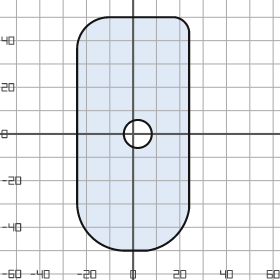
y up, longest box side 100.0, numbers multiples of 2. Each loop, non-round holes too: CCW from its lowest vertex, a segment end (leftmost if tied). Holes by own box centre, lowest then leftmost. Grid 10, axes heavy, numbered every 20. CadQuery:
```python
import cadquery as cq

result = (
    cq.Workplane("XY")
    .moveTo(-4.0, -50.0)
    .lineTo(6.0, -50.0)
    .threePointArc((18.0, -44.0), (24.0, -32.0))
    .lineTo(24.0, 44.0)
    .threePointArc((22.0, 48.0), (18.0, 50.0))
    .lineTo(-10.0, 50.0)
    .threePointArc((-20.0, 46.0), (-24.0, 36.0))
    .lineTo(-24.0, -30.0)
    .threePointArc((-18.0, -44.0), (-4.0, -50.0))
    .close()
    .moveTo(2.0, 0.0)
    .circle(6.0)
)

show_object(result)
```